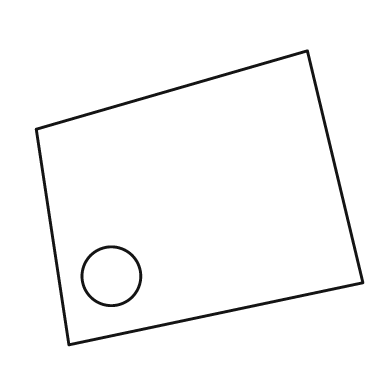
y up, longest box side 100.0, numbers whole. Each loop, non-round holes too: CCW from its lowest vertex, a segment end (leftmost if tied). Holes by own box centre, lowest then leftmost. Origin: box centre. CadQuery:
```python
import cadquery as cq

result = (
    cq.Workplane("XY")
    .moveTo(-40.0, -45.0)
    .lineTo(50.0, -26.0)
    .lineTo(33.0, 45.0)
    .lineTo(-50.0, 21.0)
    .close()
    .moveTo(-27.0, -24.0)
    .circle(9.0)
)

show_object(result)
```